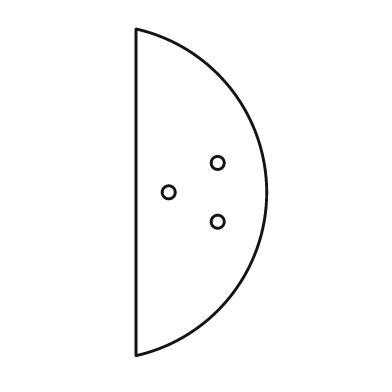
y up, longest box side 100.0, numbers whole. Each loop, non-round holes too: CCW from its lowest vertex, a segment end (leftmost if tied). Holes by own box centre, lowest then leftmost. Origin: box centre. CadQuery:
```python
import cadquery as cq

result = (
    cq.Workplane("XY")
    .moveTo(-20.0, -50.0)
    .threePointArc((20.0, 0.0), (-20.0, 50.0))
    .close()
    .moveTo(5.0, -9.0)
    .circle(2.0)
    .moveTo(-10.0, 0.0)
    .circle(2.0)
    .moveTo(5.0, 9.0)
    .circle(2.0)
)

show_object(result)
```